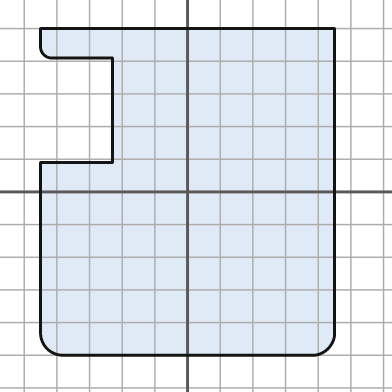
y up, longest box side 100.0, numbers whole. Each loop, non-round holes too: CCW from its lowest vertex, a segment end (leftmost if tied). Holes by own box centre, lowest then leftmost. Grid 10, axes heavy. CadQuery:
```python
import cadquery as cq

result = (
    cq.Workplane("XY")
    .moveTo(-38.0, -50.0)
    .lineTo(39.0, -50.0)
    .threePointArc((43.0, -48.0), (45.0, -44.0))
    .lineTo(45.0, 50.0)
    .lineTo(-45.0, 50.0)
    .lineTo(-45.0, 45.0)
    .threePointArc((-44.0, 42.0), (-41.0, 41.0))
    .lineTo(-23.0, 41.0)
    .lineTo(-23.0, 9.0)
    .lineTo(-45.0, 9.0)
    .lineTo(-45.0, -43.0)
    .threePointArc((-43.0, -48.0), (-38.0, -50.0))
    .close()
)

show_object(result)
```